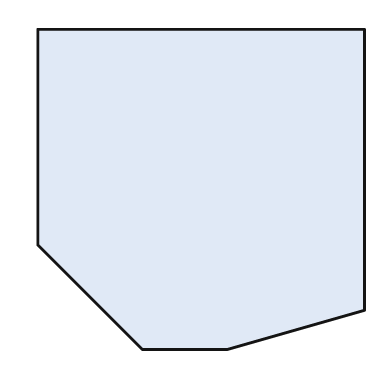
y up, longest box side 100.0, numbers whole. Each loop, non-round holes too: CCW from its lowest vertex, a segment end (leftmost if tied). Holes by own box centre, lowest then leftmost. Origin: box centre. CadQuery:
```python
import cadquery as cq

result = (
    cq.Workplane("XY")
    .moveTo(-18.0, -49.0)
    .lineTo(8.0, -49.0)
    .lineTo(50.0, -37.0)
    .lineTo(50.0, 49.0)
    .lineTo(-50.0, 49.0)
    .lineTo(-50.0, -17.0)
    .close()
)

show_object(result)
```